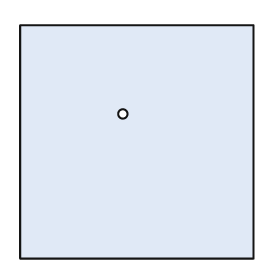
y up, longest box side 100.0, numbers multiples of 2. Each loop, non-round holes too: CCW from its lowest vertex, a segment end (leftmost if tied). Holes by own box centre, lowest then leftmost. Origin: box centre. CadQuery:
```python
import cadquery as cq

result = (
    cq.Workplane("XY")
    .moveTo(-50.0, -50.0)
    .lineTo(50.0, -50.0)
    .lineTo(50.0, 50.0)
    .lineTo(-50.0, 50.0)
    .close()
    .moveTo(-6.0, 12.0)
    .circle(2.0)
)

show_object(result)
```